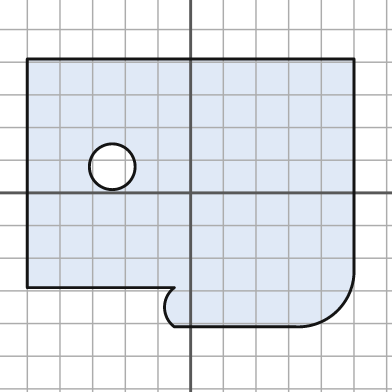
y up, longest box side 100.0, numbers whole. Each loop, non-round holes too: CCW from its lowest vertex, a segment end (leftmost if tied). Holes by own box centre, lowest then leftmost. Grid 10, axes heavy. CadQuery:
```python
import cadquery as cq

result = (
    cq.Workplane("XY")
    .moveTo(-5.0, -41.0)
    .lineTo(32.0, -41.0)
    .threePointArc((45.0, -36.0), (50.0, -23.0))
    .lineTo(50.0, 41.0)
    .lineTo(-50.0, 41.0)
    .lineTo(-50.0, -29.0)
    .lineTo(-5.0, -29.0)
    .threePointArc((-8.0, -35.0), (-5.0, -41.0))
    .close()
    .moveTo(-24.0, 8.0)
    .circle(7.0)
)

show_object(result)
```